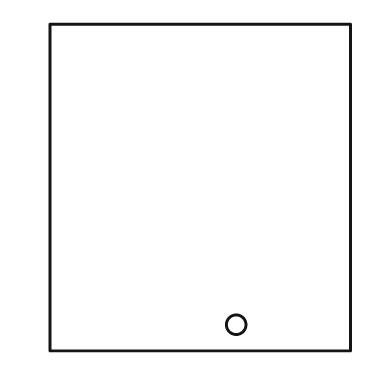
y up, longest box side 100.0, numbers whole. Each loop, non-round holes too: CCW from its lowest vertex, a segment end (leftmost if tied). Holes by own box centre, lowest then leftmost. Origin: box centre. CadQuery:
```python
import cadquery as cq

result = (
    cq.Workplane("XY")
    .moveTo(-46.0, -50.0)
    .lineTo(46.0, -50.0)
    .lineTo(46.0, 50.0)
    .lineTo(-46.0, 50.0)
    .close()
    .moveTo(11.0, -42.0)
    .circle(3.0)
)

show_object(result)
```